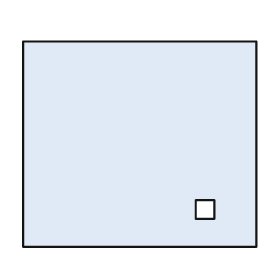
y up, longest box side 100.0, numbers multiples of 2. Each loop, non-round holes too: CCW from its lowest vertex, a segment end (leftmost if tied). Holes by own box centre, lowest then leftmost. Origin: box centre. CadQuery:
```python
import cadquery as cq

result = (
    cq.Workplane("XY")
    .moveTo(-50.0, -44.0)
    .lineTo(50.0, -44.0)
    .lineTo(50.0, 44.0)
    .lineTo(-50.0, 44.0)
    .close()
    .moveTo(24.0, -32.0)
    .lineTo(32.0, -32.0)
    .lineTo(32.0, -24.0)
    .lineTo(24.0, -24.0)
    .close()
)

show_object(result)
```